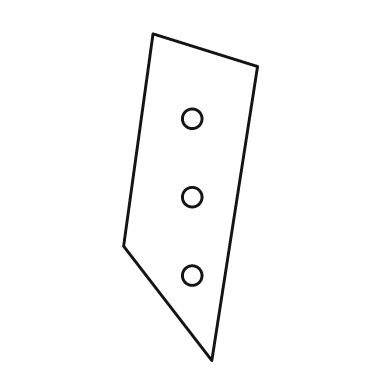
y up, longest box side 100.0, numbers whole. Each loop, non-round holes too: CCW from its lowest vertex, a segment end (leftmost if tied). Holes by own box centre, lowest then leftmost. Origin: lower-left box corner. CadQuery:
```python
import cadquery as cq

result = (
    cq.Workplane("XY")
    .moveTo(27.0, 0.0)
    .lineTo(41.0, 90.0)
    .lineTo(9.0, 100.0)
    .lineTo(0.0, 35.0)
    .close()
    .moveTo(21.0, 26.0)
    .circle(3.0)
    .moveTo(21.0, 50.0)
    .circle(3.0)
    .moveTo(21.0, 74.0)
    .circle(3.0)
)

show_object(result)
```